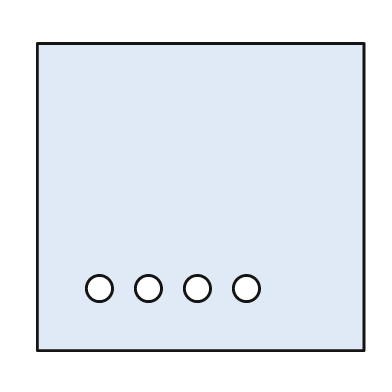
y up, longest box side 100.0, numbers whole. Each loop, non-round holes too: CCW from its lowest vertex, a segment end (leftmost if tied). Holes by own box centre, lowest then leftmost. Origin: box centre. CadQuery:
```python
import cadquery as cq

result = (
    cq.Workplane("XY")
    .moveTo(-50.0, -47.0)
    .lineTo(50.0, -47.0)
    .lineTo(50.0, 47.0)
    .lineTo(-50.0, 47.0)
    .close()
    .moveTo(-31.0, -28.0)
    .circle(4.0)
    .moveTo(-16.0, -28.0)
    .circle(4.0)
    .moveTo(-1.0, -28.0)
    .circle(4.0)
    .moveTo(14.0, -28.0)
    .circle(4.0)
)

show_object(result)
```